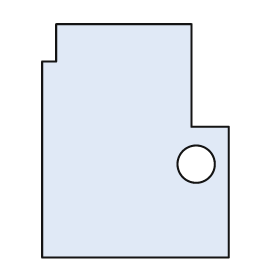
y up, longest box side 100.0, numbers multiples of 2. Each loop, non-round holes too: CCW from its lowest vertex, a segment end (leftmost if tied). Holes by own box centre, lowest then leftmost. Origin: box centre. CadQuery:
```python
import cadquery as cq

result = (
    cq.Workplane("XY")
    .moveTo(-40.0, -50.0)
    .lineTo(40.0, -50.0)
    .lineTo(40.0, 6.0)
    .lineTo(24.0, 6.0)
    .lineTo(24.0, 50.0)
    .lineTo(-34.0, 50.0)
    .lineTo(-34.0, 34.0)
    .lineTo(-40.0, 34.0)
    .close()
    .moveTo(26.0, -10.0)
    .circle(8.0)
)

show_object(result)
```